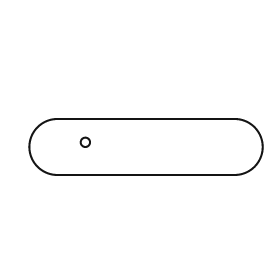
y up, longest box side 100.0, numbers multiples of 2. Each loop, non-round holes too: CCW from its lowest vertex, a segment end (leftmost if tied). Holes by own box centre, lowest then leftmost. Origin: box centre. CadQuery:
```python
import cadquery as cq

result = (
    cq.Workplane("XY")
    .moveTo(-38.0, -12.0)
    .lineTo(38.0, -12.0)
    .threePointArc((50.0, 0.0), (38.0, 12.0))
    .lineTo(-38.0, 12.0)
    .threePointArc((-50.0, 0.0), (-38.0, -12.0))
    .close()
    .moveTo(-26.0, 2.0)
    .circle(2.0)
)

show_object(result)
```